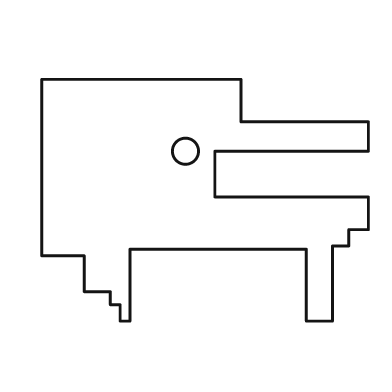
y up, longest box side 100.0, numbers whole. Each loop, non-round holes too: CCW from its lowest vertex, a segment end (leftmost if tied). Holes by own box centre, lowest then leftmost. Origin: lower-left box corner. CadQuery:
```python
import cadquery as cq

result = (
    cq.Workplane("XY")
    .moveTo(24.0, 0.0)
    .lineTo(27.0, 0.0)
    .lineTo(27.0, 22.0)
    .lineTo(81.0, 22.0)
    .lineTo(81.0, 0.0)
    .lineTo(89.0, 0.0)
    .lineTo(89.0, 23.0)
    .lineTo(94.0, 23.0)
    .lineTo(94.0, 28.0)
    .lineTo(100.0, 28.0)
    .lineTo(100.0, 38.0)
    .lineTo(53.0, 38.0)
    .lineTo(53.0, 52.0)
    .lineTo(100.0, 52.0)
    .lineTo(100.0, 61.0)
    .lineTo(61.0, 61.0)
    .lineTo(61.0, 74.0)
    .lineTo(0.0, 74.0)
    .lineTo(0.0, 20.0)
    .lineTo(13.0, 20.0)
    .lineTo(13.0, 9.0)
    .lineTo(21.0, 9.0)
    .lineTo(21.0, 5.0)
    .lineTo(24.0, 5.0)
    .close()
    .moveTo(44.0, 52.0)
    .circle(4.0)
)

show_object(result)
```